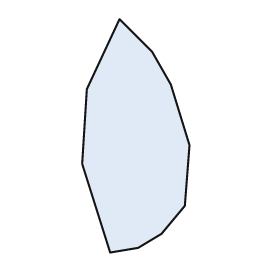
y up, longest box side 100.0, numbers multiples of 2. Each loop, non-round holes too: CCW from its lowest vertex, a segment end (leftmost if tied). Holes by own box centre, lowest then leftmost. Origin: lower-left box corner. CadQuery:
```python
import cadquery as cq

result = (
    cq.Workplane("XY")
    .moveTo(12.0, 0.0)
    .lineTo(24.0, 2.0)
    .lineTo(34.0, 8.0)
    .lineTo(44.0, 20.0)
    .lineTo(46.0, 46.0)
    .lineTo(38.0, 72.0)
    .lineTo(30.0, 86.0)
    .lineTo(16.0, 100.0)
    .lineTo(2.0, 70.0)
    .lineTo(0.0, 38.0)
    .close()
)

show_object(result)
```